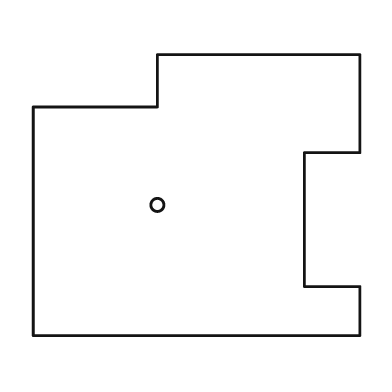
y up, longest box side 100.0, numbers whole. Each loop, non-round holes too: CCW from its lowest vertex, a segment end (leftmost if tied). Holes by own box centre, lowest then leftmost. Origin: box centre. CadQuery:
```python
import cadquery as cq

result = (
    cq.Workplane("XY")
    .moveTo(-50.0, -43.0)
    .lineTo(50.0, -43.0)
    .lineTo(50.0, -28.0)
    .lineTo(33.0, -28.0)
    .lineTo(33.0, 13.0)
    .lineTo(50.0, 13.0)
    .lineTo(50.0, 43.0)
    .lineTo(-12.0, 43.0)
    .lineTo(-12.0, 27.0)
    .lineTo(-50.0, 27.0)
    .close()
    .moveTo(-12.0, -3.0)
    .circle(2.0)
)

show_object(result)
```